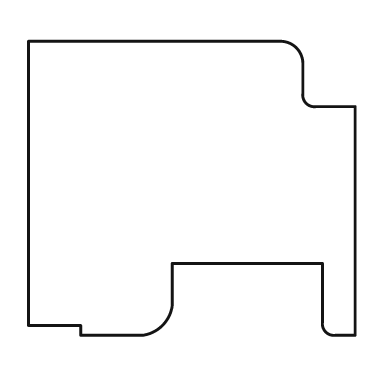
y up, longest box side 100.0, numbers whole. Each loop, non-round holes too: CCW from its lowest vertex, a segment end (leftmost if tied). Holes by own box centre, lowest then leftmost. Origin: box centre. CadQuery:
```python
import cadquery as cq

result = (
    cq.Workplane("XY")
    .moveTo(-34.0, -45.0)
    .lineTo(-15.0, -45.0)
    .threePointArc((-9.0, -42.0), (-6.0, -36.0))
    .lineTo(-6.0, -23.0)
    .lineTo(40.0, -23.0)
    .lineTo(40.0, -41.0)
    .threePointArc((41.0, -44.0), (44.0, -45.0))
    .lineTo(50.0, -45.0)
    .lineTo(50.0, 25.0)
    .lineTo(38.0, 25.0)
    .threePointArc((35.0, 26.0), (34.0, 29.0))
    .lineTo(34.0, 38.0)
    .threePointArc((32.0, 43.0), (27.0, 45.0))
    .lineTo(-50.0, 45.0)
    .lineTo(-50.0, -42.0)
    .lineTo(-34.0, -42.0)
    .close()
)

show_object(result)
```